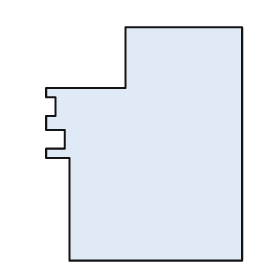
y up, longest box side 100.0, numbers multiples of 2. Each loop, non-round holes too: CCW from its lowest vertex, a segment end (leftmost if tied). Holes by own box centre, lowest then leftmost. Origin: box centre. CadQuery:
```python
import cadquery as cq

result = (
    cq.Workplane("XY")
    .moveTo(-32.0, -50.0)
    .lineTo(42.0, -50.0)
    .lineTo(42.0, 50.0)
    .lineTo(-8.0, 50.0)
    .lineTo(-8.0, 24.0)
    .lineTo(-42.0, 24.0)
    .lineTo(-42.0, 20.0)
    .lineTo(-38.0, 20.0)
    .lineTo(-38.0, 12.0)
    .lineTo(-42.0, 12.0)
    .lineTo(-42.0, 6.0)
    .lineTo(-34.0, 6.0)
    .lineTo(-34.0, -2.0)
    .lineTo(-42.0, -2.0)
    .lineTo(-42.0, -6.0)
    .lineTo(-32.0, -6.0)
    .close()
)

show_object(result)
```